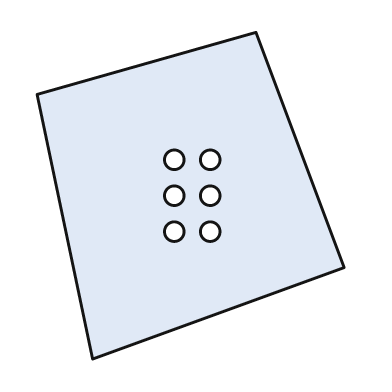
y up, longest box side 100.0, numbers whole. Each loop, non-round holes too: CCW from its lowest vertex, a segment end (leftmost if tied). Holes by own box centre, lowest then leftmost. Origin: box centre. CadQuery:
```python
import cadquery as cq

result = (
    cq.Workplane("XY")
    .moveTo(-30.0, -50.0)
    .lineTo(47.0, -22.0)
    .lineTo(20.0, 50.0)
    .lineTo(-47.0, 31.0)
    .close()
    .moveTo(-5.0, -11.0)
    .circle(3.0)
    .moveTo(6.0, -11.0)
    .circle(3.0)
    .moveTo(-5.0, 0.0)
    .circle(3.0)
    .moveTo(6.0, 0.0)
    .circle(3.0)
    .moveTo(-5.0, 11.0)
    .circle(3.0)
    .moveTo(6.0, 11.0)
    .circle(3.0)
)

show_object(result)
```